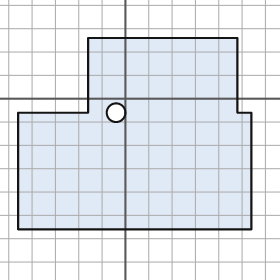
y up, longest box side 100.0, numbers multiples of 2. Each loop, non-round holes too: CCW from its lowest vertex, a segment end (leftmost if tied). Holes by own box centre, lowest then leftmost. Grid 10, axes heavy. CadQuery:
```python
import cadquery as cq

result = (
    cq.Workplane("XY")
    .moveTo(-46.0, -56.0)
    .lineTo(54.0, -56.0)
    .lineTo(54.0, -6.0)
    .lineTo(48.0, -6.0)
    .lineTo(48.0, 26.0)
    .lineTo(-16.0, 26.0)
    .lineTo(-16.0, -6.0)
    .lineTo(-46.0, -6.0)
    .close()
    .moveTo(-4.0, -6.0)
    .circle(4.0)
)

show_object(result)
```